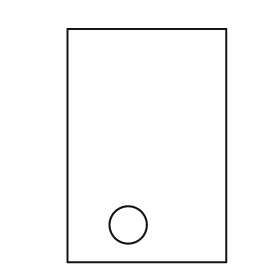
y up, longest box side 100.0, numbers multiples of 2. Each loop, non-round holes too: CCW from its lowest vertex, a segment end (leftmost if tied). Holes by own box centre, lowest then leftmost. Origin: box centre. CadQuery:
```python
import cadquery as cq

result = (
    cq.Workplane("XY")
    .moveTo(-34.0, -50.0)
    .lineTo(34.0, -50.0)
    .lineTo(34.0, 50.0)
    .lineTo(-34.0, 50.0)
    .close()
    .moveTo(-8.0, -34.0)
    .circle(8.0)
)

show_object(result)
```